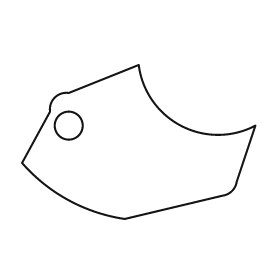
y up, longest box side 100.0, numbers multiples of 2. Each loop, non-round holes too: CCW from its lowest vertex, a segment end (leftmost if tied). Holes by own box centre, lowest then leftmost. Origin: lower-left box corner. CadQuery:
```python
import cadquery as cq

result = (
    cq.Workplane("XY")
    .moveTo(44.0, 0.0)
    .lineTo(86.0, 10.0)
    .threePointArc((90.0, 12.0), (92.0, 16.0))
    .lineTo(100.0, 40.0)
    .threePointArc((68.0, 40.0), (50.0, 66.0))
    .lineTo(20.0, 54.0)
    .threePointArc((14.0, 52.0), (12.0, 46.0))
    .lineTo(0.0, 24.0)
    .threePointArc((20.0, 8.0), (44.0, 0.0))
    .close()
    .moveTo(20.0, 40.0)
    .circle(6.0)
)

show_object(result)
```